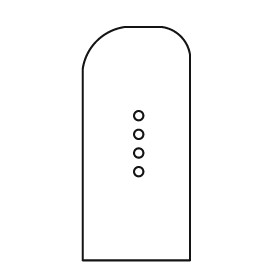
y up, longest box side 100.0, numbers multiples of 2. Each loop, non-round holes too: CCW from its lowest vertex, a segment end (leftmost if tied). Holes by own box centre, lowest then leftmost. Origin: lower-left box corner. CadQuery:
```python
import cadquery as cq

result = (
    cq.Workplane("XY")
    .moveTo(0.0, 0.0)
    .lineTo(46.0, 0.0)
    .lineTo(46.0, 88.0)
    .threePointArc((42.0, 96.0), (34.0, 100.0))
    .lineTo(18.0, 100.0)
    .threePointArc((6.0, 94.0), (0.0, 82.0))
    .close()
    .moveTo(24.0, 38.0)
    .circle(2.0)
    .moveTo(24.0, 46.0)
    .circle(2.0)
    .moveTo(24.0, 54.0)
    .circle(2.0)
    .moveTo(24.0, 62.0)
    .circle(2.0)
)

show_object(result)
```